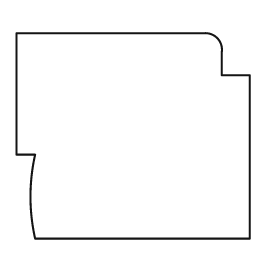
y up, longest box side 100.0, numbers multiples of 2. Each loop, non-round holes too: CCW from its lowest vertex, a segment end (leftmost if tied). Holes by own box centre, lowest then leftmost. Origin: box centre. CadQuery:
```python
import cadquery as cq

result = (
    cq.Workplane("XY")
    .moveTo(-42.0, -44.0)
    .lineTo(50.0, -44.0)
    .lineTo(50.0, 26.0)
    .lineTo(38.0, 26.0)
    .lineTo(38.0, 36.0)
    .threePointArc((36.0, 42.0), (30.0, 44.0))
    .lineTo(-50.0, 44.0)
    .lineTo(-50.0, -8.0)
    .lineTo(-42.0, -8.0)
    .threePointArc((-44.0, -26.0), (-42.0, -44.0))
    .close()
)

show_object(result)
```